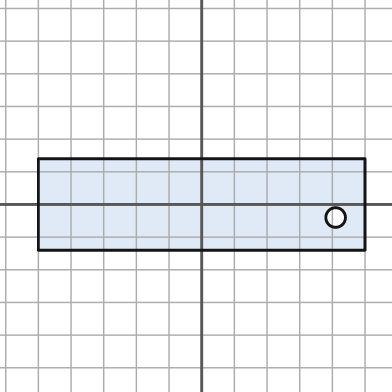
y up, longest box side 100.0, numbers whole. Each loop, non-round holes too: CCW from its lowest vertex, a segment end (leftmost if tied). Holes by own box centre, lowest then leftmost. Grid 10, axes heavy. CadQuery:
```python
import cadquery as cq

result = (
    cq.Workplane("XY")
    .moveTo(-50.0, -14.0)
    .lineTo(50.0, -14.0)
    .lineTo(50.0, 14.0)
    .lineTo(-50.0, 14.0)
    .close()
    .moveTo(41.0, -4.0)
    .circle(3.0)
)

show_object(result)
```